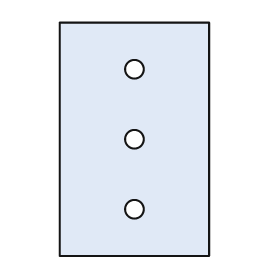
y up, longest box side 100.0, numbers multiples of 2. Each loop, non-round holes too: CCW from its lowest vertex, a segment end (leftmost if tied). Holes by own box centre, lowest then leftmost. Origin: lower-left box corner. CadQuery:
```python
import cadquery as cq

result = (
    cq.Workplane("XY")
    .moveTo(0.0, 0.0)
    .lineTo(64.0, 0.0)
    .lineTo(64.0, 100.0)
    .lineTo(0.0, 100.0)
    .close()
    .moveTo(32.0, 20.0)
    .circle(4.0)
    .moveTo(32.0, 50.0)
    .circle(4.0)
    .moveTo(32.0, 80.0)
    .circle(4.0)
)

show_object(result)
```